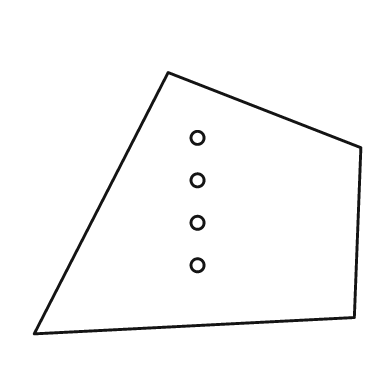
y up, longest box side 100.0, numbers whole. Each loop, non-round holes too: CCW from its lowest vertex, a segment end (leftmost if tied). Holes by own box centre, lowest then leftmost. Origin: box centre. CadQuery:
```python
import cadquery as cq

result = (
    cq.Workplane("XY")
    .moveTo(-50.0, -40.0)
    .lineTo(48.0, -35.0)
    .lineTo(50.0, 17.0)
    .lineTo(-9.0, 40.0)
    .close()
    .moveTo(0.0, -19.0)
    .circle(2.0)
    .moveTo(0.0, -6.0)
    .circle(2.0)
    .moveTo(0.0, 7.0)
    .circle(2.0)
    .moveTo(0.0, 20.0)
    .circle(2.0)
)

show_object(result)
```